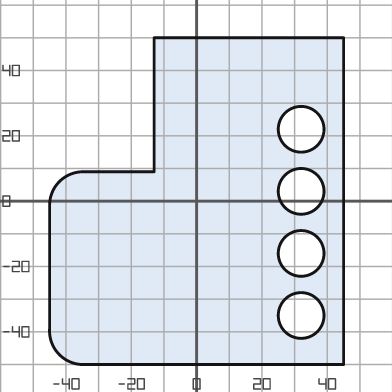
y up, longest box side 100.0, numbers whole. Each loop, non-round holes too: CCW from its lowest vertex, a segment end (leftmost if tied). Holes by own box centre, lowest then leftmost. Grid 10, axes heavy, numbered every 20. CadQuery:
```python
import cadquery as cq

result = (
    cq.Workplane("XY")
    .moveTo(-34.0, -50.0)
    .lineTo(45.0, -50.0)
    .lineTo(45.0, 50.0)
    .lineTo(-13.0, 50.0)
    .lineTo(-13.0, 9.0)
    .lineTo(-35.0, 9.0)
    .threePointArc((-42.0, 6.0), (-45.0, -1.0))
    .lineTo(-45.0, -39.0)
    .threePointArc((-42.0, -47.0), (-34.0, -50.0))
    .close()
    .moveTo(32.0, -35.0)
    .circle(7.0)
    .moveTo(32.0, -16.0)
    .circle(7.0)
    .moveTo(32.0, 3.0)
    .circle(7.0)
    .moveTo(32.0, 22.0)
    .circle(7.0)
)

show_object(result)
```